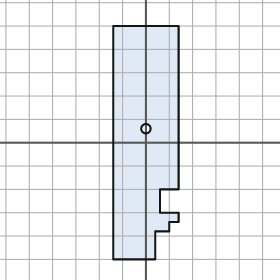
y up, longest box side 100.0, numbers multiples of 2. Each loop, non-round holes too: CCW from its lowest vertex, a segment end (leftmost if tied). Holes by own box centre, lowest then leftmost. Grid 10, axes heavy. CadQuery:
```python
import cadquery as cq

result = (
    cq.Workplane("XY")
    .moveTo(-14.0, -50.0)
    .lineTo(4.0, -50.0)
    .lineTo(4.0, -38.0)
    .lineTo(10.0, -38.0)
    .lineTo(10.0, -34.0)
    .lineTo(14.0, -34.0)
    .lineTo(14.0, -30.0)
    .lineTo(6.0, -30.0)
    .lineTo(6.0, -20.0)
    .lineTo(14.0, -20.0)
    .lineTo(14.0, 50.0)
    .lineTo(-14.0, 50.0)
    .close()
    .moveTo(0.0, 6.0)
    .circle(2.0)
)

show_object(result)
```